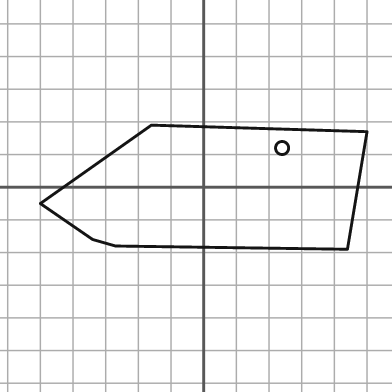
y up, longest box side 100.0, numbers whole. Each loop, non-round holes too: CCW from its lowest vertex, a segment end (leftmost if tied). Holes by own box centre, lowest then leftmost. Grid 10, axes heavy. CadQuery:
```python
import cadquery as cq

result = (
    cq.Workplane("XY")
    .moveTo(44.0, -19.0)
    .lineTo(50.0, 17.0)
    .lineTo(-16.0, 19.0)
    .lineTo(-50.0, -5.0)
    .lineTo(-34.0, -16.0)
    .lineTo(-27.0, -18.0)
    .close()
    .moveTo(24.0, 12.0)
    .circle(2.0)
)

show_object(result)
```